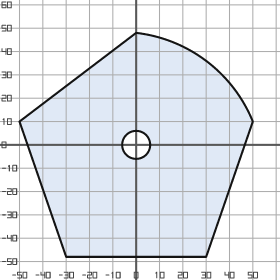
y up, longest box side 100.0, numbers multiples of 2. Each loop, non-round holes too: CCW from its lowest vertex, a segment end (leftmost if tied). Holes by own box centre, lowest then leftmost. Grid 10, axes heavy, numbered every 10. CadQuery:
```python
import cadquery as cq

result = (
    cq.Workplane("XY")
    .moveTo(-30.0, -48.0)
    .lineTo(30.0, -48.0)
    .lineTo(50.0, 10.0)
    .threePointArc((30.0, 36.0), (0.0, 48.0))
    .lineTo(-50.0, 10.0)
    .close()
    .moveTo(0.0, 0.0)
    .circle(6.0)
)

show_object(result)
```